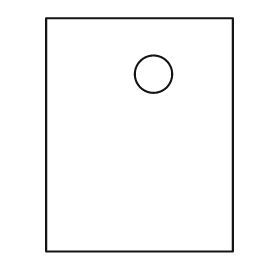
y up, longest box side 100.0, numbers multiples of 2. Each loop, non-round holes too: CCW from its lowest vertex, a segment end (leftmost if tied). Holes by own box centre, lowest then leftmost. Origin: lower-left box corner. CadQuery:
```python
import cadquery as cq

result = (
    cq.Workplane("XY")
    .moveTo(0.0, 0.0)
    .lineTo(80.0, 0.0)
    .lineTo(80.0, 100.0)
    .lineTo(0.0, 100.0)
    .close()
    .moveTo(46.0, 76.0)
    .circle(8.0)
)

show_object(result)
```